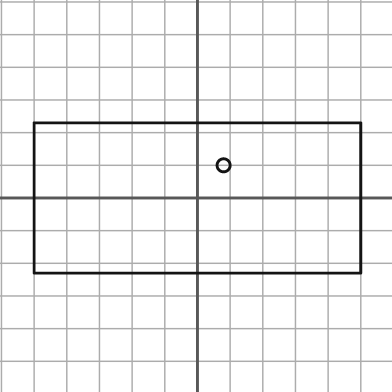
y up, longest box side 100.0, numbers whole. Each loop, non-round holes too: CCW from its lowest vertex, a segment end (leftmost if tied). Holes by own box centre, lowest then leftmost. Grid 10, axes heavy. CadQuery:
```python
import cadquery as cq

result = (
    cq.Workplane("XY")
    .moveTo(-50.0, -23.0)
    .lineTo(50.0, -23.0)
    .lineTo(50.0, 23.0)
    .lineTo(-50.0, 23.0)
    .close()
    .moveTo(8.0, 10.0)
    .circle(2.0)
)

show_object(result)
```